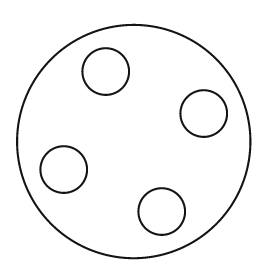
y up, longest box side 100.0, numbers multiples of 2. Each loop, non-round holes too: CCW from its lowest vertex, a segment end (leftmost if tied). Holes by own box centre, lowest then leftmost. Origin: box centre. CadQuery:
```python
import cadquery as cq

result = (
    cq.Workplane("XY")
    .moveTo(0.0, 0.0)
    .circle(50.0)
    .moveTo(12.0, -30.0)
    .circle(10.0)
    .moveTo(-30.0, -12.0)
    .circle(10.0)
    .moveTo(30.0, 12.0)
    .circle(10.0)
    .moveTo(-12.0, 30.0)
    .circle(10.0)
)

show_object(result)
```